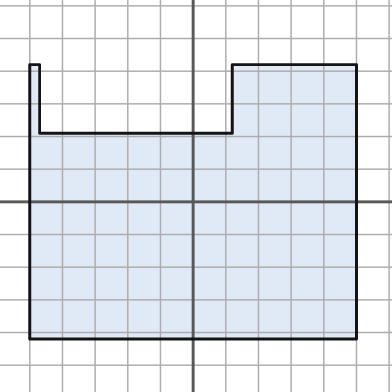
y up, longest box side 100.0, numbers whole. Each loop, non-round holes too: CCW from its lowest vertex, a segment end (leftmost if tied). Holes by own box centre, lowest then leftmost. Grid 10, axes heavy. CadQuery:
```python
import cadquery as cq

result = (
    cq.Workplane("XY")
    .moveTo(-50.0, -42.0)
    .lineTo(50.0, -42.0)
    .lineTo(50.0, 42.0)
    .lineTo(12.0, 42.0)
    .lineTo(12.0, 21.0)
    .lineTo(-47.0, 21.0)
    .lineTo(-47.0, 42.0)
    .lineTo(-50.0, 42.0)
    .close()
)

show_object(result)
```